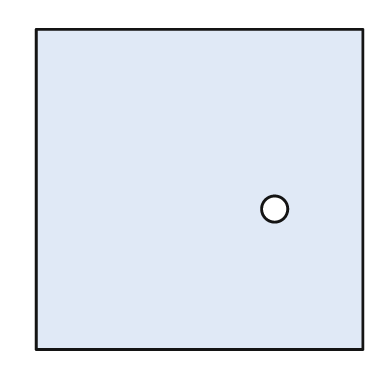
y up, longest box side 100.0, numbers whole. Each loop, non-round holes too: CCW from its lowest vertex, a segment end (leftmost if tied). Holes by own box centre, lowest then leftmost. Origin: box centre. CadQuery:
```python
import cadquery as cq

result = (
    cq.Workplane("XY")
    .moveTo(-50.0, -49.0)
    .lineTo(50.0, -49.0)
    .lineTo(50.0, 49.0)
    .lineTo(-50.0, 49.0)
    .close()
    .moveTo(23.0, -6.0)
    .circle(4.0)
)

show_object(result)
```